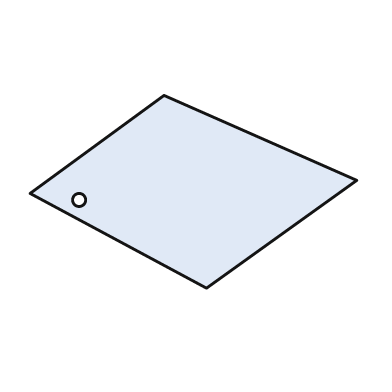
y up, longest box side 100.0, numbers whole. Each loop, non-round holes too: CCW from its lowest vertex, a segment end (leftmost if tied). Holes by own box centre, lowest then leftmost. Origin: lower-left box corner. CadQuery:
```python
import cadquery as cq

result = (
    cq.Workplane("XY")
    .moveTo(54.0, 0.0)
    .lineTo(100.0, 33.0)
    .lineTo(41.0, 59.0)
    .lineTo(0.0, 29.0)
    .close()
    .moveTo(15.0, 27.0)
    .circle(2.0)
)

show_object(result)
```